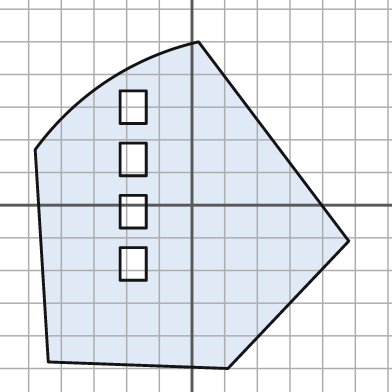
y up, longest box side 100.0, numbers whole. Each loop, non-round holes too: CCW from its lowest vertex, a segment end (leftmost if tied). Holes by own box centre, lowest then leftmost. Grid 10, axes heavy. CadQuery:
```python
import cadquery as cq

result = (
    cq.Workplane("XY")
    .moveTo(11.0, -50.0)
    .lineTo(48.0, -11.0)
    .lineTo(2.0, 50.0)
    .threePointArc((-26.0, 38.0), (-48.0, 17.0))
    .lineTo(-44.0, -48.0)
    .close()
    .moveTo(-22.0, -23.0)
    .lineTo(-14.0, -23.0)
    .lineTo(-14.0, -13.0)
    .lineTo(-22.0, -13.0)
    .close()
    .moveTo(-22.0, -7.0)
    .lineTo(-14.0, -7.0)
    .lineTo(-14.0, 3.0)
    .lineTo(-22.0, 3.0)
    .close()
    .moveTo(-22.0, 9.0)
    .lineTo(-14.0, 9.0)
    .lineTo(-14.0, 19.0)
    .lineTo(-22.0, 19.0)
    .close()
    .moveTo(-22.0, 25.0)
    .lineTo(-14.0, 25.0)
    .lineTo(-14.0, 35.0)
    .lineTo(-22.0, 35.0)
    .close()
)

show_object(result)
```